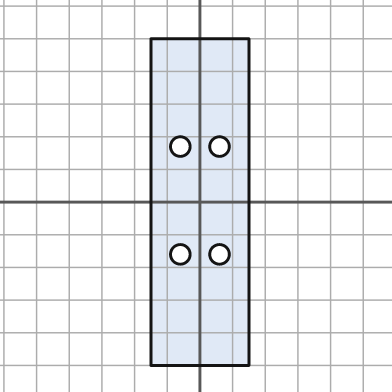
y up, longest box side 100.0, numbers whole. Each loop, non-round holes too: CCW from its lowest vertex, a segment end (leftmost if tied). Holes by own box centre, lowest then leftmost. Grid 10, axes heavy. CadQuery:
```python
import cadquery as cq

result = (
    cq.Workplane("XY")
    .moveTo(-15.0, -50.0)
    .lineTo(15.0, -50.0)
    .lineTo(15.0, 50.0)
    .lineTo(-15.0, 50.0)
    .close()
    .moveTo(-6.0, -16.0)
    .circle(3.0)
    .moveTo(6.0, -16.0)
    .circle(3.0)
    .moveTo(-6.0, 17.0)
    .circle(3.0)
    .moveTo(6.0, 17.0)
    .circle(3.0)
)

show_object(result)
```